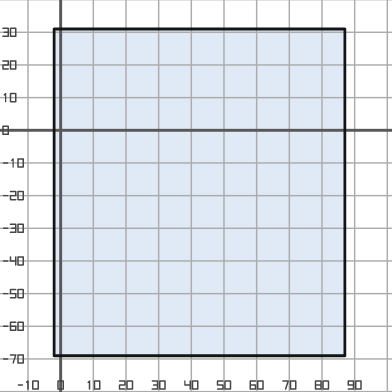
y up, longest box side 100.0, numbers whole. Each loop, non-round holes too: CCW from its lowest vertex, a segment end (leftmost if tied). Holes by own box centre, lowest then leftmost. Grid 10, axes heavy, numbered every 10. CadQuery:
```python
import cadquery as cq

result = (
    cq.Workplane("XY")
    .moveTo(-2.0, -69.0)
    .lineTo(87.0, -69.0)
    .lineTo(87.0, 31.0)
    .lineTo(-2.0, 31.0)
    .close()
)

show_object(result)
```